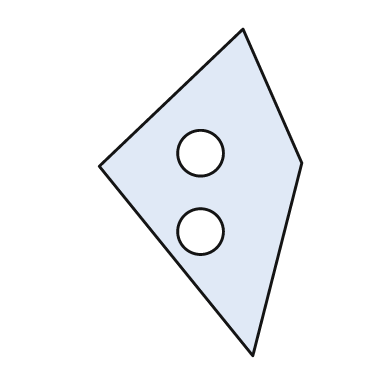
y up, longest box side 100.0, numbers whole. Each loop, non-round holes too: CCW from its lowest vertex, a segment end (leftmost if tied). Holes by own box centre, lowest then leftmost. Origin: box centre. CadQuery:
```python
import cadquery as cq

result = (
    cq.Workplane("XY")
    .moveTo(16.0, -50.0)
    .lineTo(31.0, 9.0)
    .lineTo(13.0, 50.0)
    .lineTo(-31.0, 8.0)
    .close()
    .moveTo(0.0, -12.0)
    .circle(7.0)
    .moveTo(0.0, 12.0)
    .circle(7.0)
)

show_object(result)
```